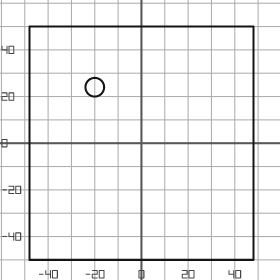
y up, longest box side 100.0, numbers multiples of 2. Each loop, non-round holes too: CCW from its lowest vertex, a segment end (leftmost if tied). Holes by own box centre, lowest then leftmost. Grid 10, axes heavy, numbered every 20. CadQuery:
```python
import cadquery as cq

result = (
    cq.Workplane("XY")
    .moveTo(-48.0, -50.0)
    .lineTo(48.0, -50.0)
    .lineTo(48.0, 50.0)
    .lineTo(-48.0, 50.0)
    .close()
    .moveTo(-20.0, 24.0)
    .circle(4.0)
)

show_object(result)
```